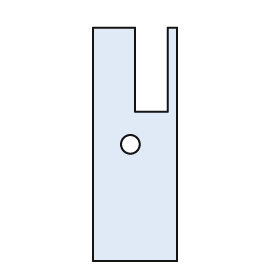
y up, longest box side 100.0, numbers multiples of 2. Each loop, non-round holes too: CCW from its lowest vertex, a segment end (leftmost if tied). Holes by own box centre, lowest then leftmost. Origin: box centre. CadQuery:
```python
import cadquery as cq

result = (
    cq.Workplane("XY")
    .moveTo(-18.0, -50.0)
    .lineTo(18.0, -50.0)
    .lineTo(18.0, 50.0)
    .lineTo(14.0, 50.0)
    .lineTo(14.0, 14.0)
    .lineTo(0.0, 14.0)
    .lineTo(0.0, 50.0)
    .lineTo(-18.0, 50.0)
    .close()
    .moveTo(-2.0, 0.0)
    .circle(4.0)
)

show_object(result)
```